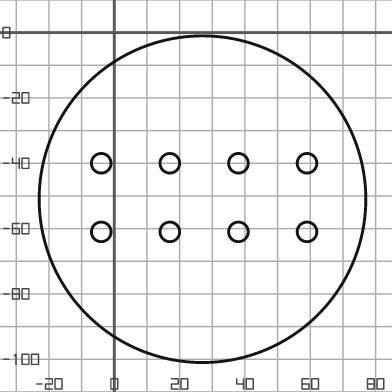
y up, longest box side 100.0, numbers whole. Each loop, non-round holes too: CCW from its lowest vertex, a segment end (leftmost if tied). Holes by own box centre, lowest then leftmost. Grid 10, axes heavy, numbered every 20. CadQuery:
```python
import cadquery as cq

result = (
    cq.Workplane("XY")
    .moveTo(27.0, -51.0)
    .circle(50.0)
    .moveTo(-4.0, -61.0)
    .circle(3.0)
    .moveTo(17.0, -61.0)
    .circle(3.0)
    .moveTo(38.0, -61.0)
    .circle(3.0)
    .moveTo(59.0, -61.0)
    .circle(3.0)
    .moveTo(-4.0, -40.0)
    .circle(3.0)
    .moveTo(17.0, -40.0)
    .circle(3.0)
    .moveTo(38.0, -40.0)
    .circle(3.0)
    .moveTo(59.0, -40.0)
    .circle(3.0)
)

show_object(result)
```